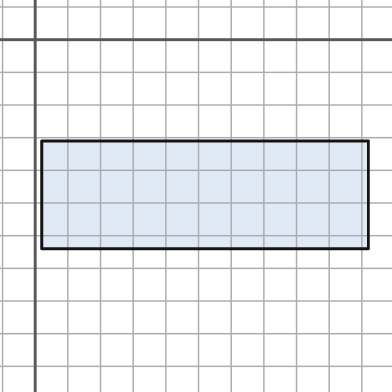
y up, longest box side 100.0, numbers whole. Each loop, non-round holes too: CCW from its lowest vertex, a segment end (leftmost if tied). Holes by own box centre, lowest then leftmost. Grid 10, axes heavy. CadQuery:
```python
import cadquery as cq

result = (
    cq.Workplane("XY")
    .moveTo(2.0, -64.0)
    .lineTo(102.0, -64.0)
    .lineTo(102.0, -31.0)
    .lineTo(2.0, -31.0)
    .close()
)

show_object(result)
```